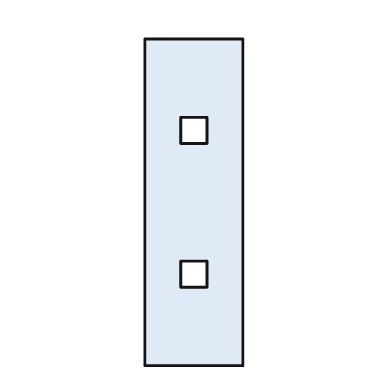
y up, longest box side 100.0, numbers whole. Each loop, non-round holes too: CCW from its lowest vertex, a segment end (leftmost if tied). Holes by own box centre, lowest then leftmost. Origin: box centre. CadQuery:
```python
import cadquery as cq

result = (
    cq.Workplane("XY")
    .moveTo(-15.0, -50.0)
    .lineTo(15.0, -50.0)
    .lineTo(15.0, 50.0)
    .lineTo(-15.0, 50.0)
    .close()
    .moveTo(-4.0, -26.0)
    .lineTo(4.0, -26.0)
    .lineTo(4.0, -18.0)
    .lineTo(-4.0, -18.0)
    .close()
    .moveTo(-4.0, 18.0)
    .lineTo(4.0, 18.0)
    .lineTo(4.0, 26.0)
    .lineTo(-4.0, 26.0)
    .close()
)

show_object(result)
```